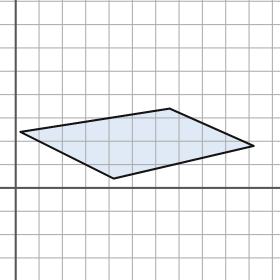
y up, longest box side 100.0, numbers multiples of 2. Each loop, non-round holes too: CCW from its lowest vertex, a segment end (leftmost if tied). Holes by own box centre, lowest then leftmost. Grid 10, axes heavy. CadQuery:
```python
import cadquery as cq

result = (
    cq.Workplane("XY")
    .moveTo(42.0, 4.0)
    .lineTo(102.0, 18.0)
    .lineTo(66.0, 34.0)
    .lineTo(2.0, 24.0)
    .close()
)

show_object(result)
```